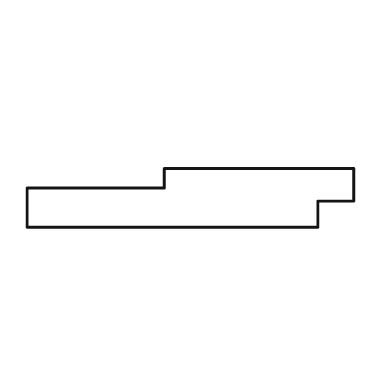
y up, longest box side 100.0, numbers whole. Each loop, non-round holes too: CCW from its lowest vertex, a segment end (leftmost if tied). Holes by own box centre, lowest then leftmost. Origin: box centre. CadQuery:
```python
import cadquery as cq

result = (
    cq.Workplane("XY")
    .moveTo(-50.0, -9.0)
    .lineTo(39.0, -9.0)
    .lineTo(39.0, -1.0)
    .lineTo(50.0, -1.0)
    .lineTo(50.0, 9.0)
    .lineTo(-8.0, 9.0)
    .lineTo(-8.0, 3.0)
    .lineTo(-50.0, 3.0)
    .close()
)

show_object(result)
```